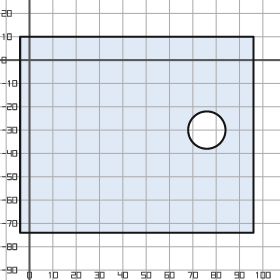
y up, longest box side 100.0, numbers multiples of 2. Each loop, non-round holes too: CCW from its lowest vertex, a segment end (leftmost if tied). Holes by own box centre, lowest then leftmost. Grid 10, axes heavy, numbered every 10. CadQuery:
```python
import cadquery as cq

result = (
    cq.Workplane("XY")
    .moveTo(-4.0, -74.0)
    .lineTo(96.0, -74.0)
    .lineTo(96.0, 10.0)
    .lineTo(-4.0, 10.0)
    .close()
    .moveTo(76.0, -30.0)
    .circle(8.0)
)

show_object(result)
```